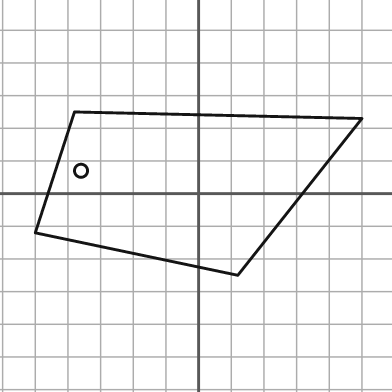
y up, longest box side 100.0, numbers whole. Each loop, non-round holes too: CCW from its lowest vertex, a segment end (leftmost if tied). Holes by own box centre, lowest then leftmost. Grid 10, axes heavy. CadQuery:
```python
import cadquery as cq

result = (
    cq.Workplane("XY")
    .moveTo(12.0, -25.0)
    .lineTo(50.0, 23.0)
    .lineTo(-38.0, 25.0)
    .lineTo(-50.0, -12.0)
    .close()
    .moveTo(-36.0, 7.0)
    .circle(2.0)
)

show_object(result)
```